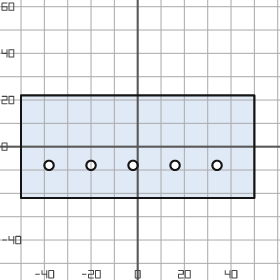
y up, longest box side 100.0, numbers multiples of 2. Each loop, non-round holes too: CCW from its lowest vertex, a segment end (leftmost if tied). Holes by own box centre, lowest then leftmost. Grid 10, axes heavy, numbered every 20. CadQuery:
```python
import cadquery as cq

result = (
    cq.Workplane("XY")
    .moveTo(-50.0, -22.0)
    .lineTo(50.0, -22.0)
    .lineTo(50.0, 22.0)
    .lineTo(-50.0, 22.0)
    .close()
    .moveTo(-38.0, -8.0)
    .circle(2.0)
    .moveTo(-20.0, -8.0)
    .circle(2.0)
    .moveTo(-2.0, -8.0)
    .circle(2.0)
    .moveTo(16.0, -8.0)
    .circle(2.0)
    .moveTo(34.0, -8.0)
    .circle(2.0)
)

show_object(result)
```